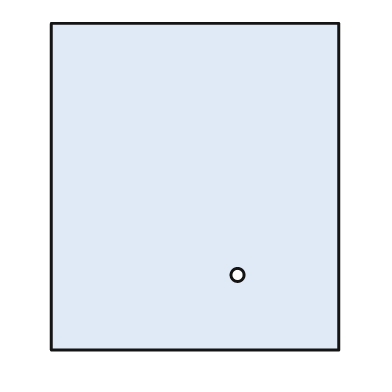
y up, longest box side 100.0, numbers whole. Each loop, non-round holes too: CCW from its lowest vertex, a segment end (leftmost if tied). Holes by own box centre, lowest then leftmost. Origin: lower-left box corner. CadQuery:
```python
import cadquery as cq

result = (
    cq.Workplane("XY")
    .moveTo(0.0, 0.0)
    .lineTo(88.0, 0.0)
    .lineTo(88.0, 100.0)
    .lineTo(0.0, 100.0)
    .close()
    .moveTo(57.0, 23.0)
    .circle(2.0)
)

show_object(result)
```